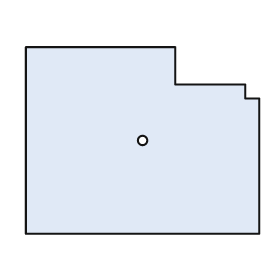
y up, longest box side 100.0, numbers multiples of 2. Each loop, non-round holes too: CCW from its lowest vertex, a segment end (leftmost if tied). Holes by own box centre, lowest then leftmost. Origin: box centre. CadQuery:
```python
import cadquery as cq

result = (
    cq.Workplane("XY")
    .moveTo(-50.0, -40.0)
    .lineTo(50.0, -40.0)
    .lineTo(50.0, 18.0)
    .lineTo(44.0, 18.0)
    .lineTo(44.0, 24.0)
    .lineTo(14.0, 24.0)
    .lineTo(14.0, 40.0)
    .lineTo(-50.0, 40.0)
    .close()
    .moveTo(0.0, 0.0)
    .circle(2.0)
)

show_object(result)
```